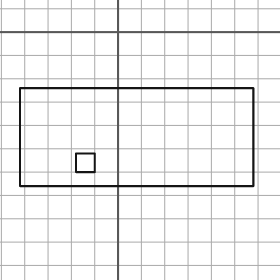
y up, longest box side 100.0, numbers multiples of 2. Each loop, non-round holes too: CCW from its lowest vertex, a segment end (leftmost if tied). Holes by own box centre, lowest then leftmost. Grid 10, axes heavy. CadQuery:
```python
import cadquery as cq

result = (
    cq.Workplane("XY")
    .moveTo(-42.0, -66.0)
    .lineTo(58.0, -66.0)
    .lineTo(58.0, -24.0)
    .lineTo(-42.0, -24.0)
    .close()
    .moveTo(-18.0, -60.0)
    .lineTo(-10.0, -60.0)
    .lineTo(-10.0, -52.0)
    .lineTo(-18.0, -52.0)
    .close()
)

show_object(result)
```